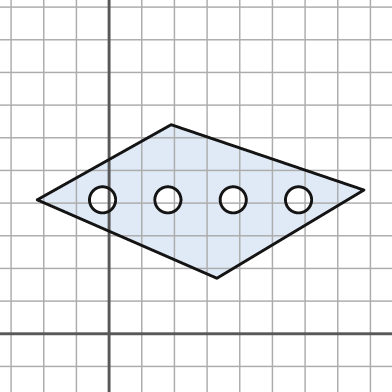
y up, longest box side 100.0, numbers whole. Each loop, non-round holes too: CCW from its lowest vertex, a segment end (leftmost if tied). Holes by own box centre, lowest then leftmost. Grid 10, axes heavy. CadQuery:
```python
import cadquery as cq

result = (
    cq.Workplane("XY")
    .moveTo(33.0, 17.0)
    .lineTo(78.0, 44.0)
    .lineTo(19.0, 64.0)
    .lineTo(-22.0, 41.0)
    .close()
    .moveTo(-2.0, 41.0)
    .circle(4.0)
    .moveTo(18.0, 41.0)
    .circle(4.0)
    .moveTo(38.0, 41.0)
    .circle(4.0)
    .moveTo(58.0, 41.0)
    .circle(4.0)
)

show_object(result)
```